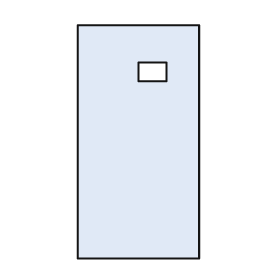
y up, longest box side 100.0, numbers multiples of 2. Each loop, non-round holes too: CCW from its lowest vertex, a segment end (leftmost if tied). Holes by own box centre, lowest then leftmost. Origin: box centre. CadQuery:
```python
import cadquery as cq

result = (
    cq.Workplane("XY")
    .moveTo(-26.0, -50.0)
    .lineTo(26.0, -50.0)
    .lineTo(26.0, 50.0)
    .lineTo(-26.0, 50.0)
    .close()
    .moveTo(0.0, 26.0)
    .lineTo(12.0, 26.0)
    .lineTo(12.0, 34.0)
    .lineTo(0.0, 34.0)
    .close()
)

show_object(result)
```